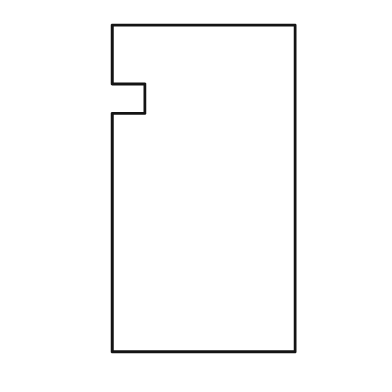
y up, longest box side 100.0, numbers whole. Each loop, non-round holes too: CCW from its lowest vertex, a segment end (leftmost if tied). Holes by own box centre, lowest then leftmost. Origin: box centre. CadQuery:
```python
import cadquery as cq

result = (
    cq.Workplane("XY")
    .moveTo(-28.0, -50.0)
    .lineTo(28.0, -50.0)
    .lineTo(28.0, 50.0)
    .lineTo(-28.0, 50.0)
    .lineTo(-28.0, 32.0)
    .lineTo(-18.0, 32.0)
    .lineTo(-18.0, 23.0)
    .lineTo(-28.0, 23.0)
    .close()
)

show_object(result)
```